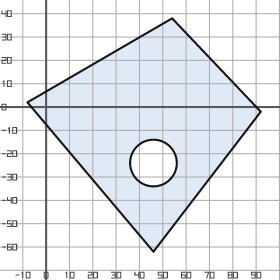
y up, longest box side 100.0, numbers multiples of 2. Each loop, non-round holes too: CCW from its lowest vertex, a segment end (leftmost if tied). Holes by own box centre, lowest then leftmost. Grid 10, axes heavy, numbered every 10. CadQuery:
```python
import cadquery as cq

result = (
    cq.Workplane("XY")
    .moveTo(46.0, -62.0)
    .lineTo(92.0, -2.0)
    .lineTo(54.0, 38.0)
    .lineTo(-8.0, 2.0)
    .close()
    .moveTo(46.0, -24.0)
    .circle(10.0)
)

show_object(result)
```